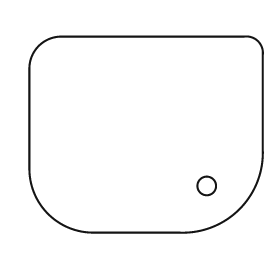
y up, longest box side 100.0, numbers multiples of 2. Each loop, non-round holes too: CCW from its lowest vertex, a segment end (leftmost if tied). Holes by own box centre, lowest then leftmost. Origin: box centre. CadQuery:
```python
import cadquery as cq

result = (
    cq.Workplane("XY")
    .moveTo(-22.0, -42.0)
    .lineTo(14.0, -42.0)
    .threePointArc((40.0, -32.0), (50.0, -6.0))
    .lineTo(50.0, 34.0)
    .threePointArc((48.0, 40.0), (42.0, 42.0))
    .lineTo(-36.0, 42.0)
    .threePointArc((-46.0, 38.0), (-50.0, 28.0))
    .lineTo(-50.0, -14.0)
    .threePointArc((-42.0, -34.0), (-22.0, -42.0))
    .close()
    .moveTo(26.0, -22.0)
    .circle(4.0)
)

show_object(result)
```